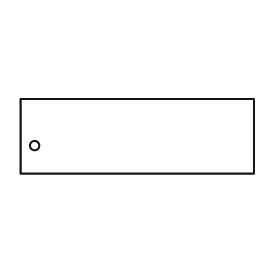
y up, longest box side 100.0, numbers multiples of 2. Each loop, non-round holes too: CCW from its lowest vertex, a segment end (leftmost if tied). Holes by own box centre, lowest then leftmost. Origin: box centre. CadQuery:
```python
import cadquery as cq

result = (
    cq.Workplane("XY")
    .moveTo(-50.0, -16.0)
    .lineTo(50.0, -16.0)
    .lineTo(50.0, 16.0)
    .lineTo(-50.0, 16.0)
    .close()
    .moveTo(-44.0, -4.0)
    .circle(2.0)
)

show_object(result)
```